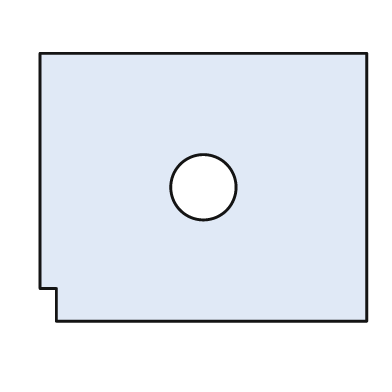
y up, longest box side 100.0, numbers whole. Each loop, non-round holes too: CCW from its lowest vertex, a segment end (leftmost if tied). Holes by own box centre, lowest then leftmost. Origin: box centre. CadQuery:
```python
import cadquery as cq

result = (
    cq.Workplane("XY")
    .moveTo(-45.0, -41.0)
    .lineTo(50.0, -41.0)
    .lineTo(50.0, 41.0)
    .lineTo(-50.0, 41.0)
    .lineTo(-50.0, -31.0)
    .lineTo(-45.0, -31.0)
    .close()
    .moveTo(0.0, 0.0)
    .circle(10.0)
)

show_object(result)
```